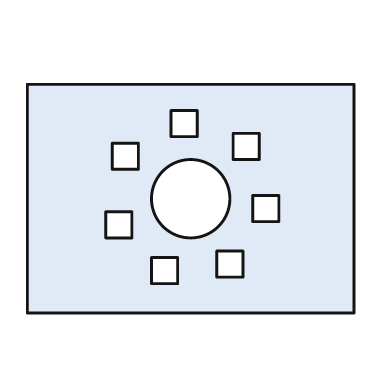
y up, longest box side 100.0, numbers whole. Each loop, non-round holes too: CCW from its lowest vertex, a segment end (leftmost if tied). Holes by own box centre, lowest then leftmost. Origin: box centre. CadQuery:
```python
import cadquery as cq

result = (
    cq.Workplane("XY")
    .moveTo(-50.0, -35.0)
    .lineTo(50.0, -35.0)
    .lineTo(50.0, 35.0)
    .lineTo(-50.0, 35.0)
    .close()
    .moveTo(-12.0, -26.0)
    .lineTo(-4.0, -26.0)
    .lineTo(-4.0, -18.0)
    .lineTo(-12.0, -18.0)
    .close()
    .moveTo(8.0, -24.0)
    .lineTo(16.0, -24.0)
    .lineTo(16.0, -16.0)
    .lineTo(8.0, -16.0)
    .close()
    .moveTo(-26.0, -12.0)
    .lineTo(-18.0, -12.0)
    .lineTo(-18.0, -4.0)
    .lineTo(-26.0, -4.0)
    .close()
    .moveTo(19.0, -7.0)
    .lineTo(27.0, -7.0)
    .lineTo(27.0, 1.0)
    .lineTo(19.0, 1.0)
    .close()
    .moveTo(0.0, 0.0)
    .circle(12.0)
    .moveTo(-24.0, 9.0)
    .lineTo(-16.0, 9.0)
    .lineTo(-16.0, 17.0)
    .lineTo(-24.0, 17.0)
    .close()
    .moveTo(13.0, 12.0)
    .lineTo(21.0, 12.0)
    .lineTo(21.0, 20.0)
    .lineTo(13.0, 20.0)
    .close()
    .moveTo(-6.0, 19.0)
    .lineTo(2.0, 19.0)
    .lineTo(2.0, 27.0)
    .lineTo(-6.0, 27.0)
    .close()
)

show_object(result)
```